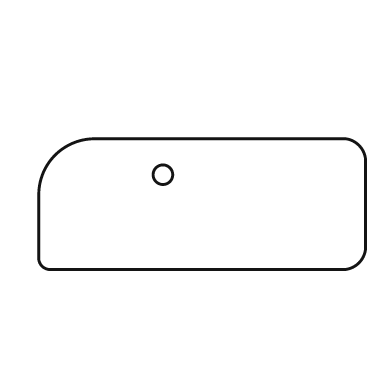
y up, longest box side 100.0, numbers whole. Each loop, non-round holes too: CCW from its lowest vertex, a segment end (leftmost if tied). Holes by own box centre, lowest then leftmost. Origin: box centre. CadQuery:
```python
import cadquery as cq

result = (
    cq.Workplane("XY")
    .moveTo(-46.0, -20.0)
    .lineTo(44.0, -20.0)
    .threePointArc((48.0, -18.0), (50.0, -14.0))
    .lineTo(50.0, 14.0)
    .threePointArc((48.0, 18.0), (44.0, 20.0))
    .lineTo(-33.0, 20.0)
    .threePointArc((-45.0, 15.0), (-50.0, 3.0))
    .lineTo(-50.0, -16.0)
    .threePointArc((-49.0, -19.0), (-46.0, -20.0))
    .close()
    .moveTo(-12.0, 9.0)
    .circle(3.0)
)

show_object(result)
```